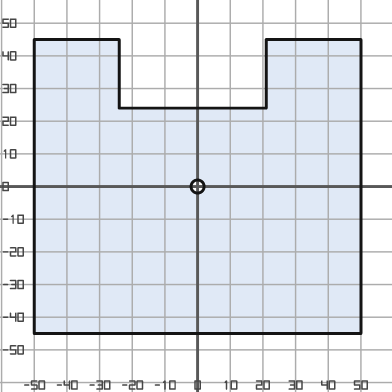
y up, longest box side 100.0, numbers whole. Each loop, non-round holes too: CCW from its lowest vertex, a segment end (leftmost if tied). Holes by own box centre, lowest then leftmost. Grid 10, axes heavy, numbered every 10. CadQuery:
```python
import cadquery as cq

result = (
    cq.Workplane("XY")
    .moveTo(-50.0, -45.0)
    .lineTo(50.0, -45.0)
    .lineTo(50.0, 45.0)
    .lineTo(21.0, 45.0)
    .lineTo(21.0, 24.0)
    .lineTo(-24.0, 24.0)
    .lineTo(-24.0, 45.0)
    .lineTo(-50.0, 45.0)
    .close()
    .moveTo(0.0, 0.0)
    .circle(2.0)
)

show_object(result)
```